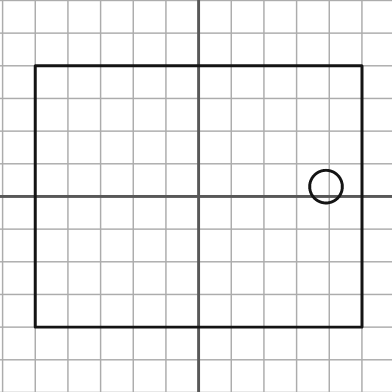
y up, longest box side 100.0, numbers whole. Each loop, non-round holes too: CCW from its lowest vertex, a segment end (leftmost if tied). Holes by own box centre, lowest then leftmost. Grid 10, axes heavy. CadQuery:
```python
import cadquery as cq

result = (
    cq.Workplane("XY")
    .moveTo(-50.0, -40.0)
    .lineTo(50.0, -40.0)
    .lineTo(50.0, 40.0)
    .lineTo(-50.0, 40.0)
    .close()
    .moveTo(39.0, 3.0)
    .circle(5.0)
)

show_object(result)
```